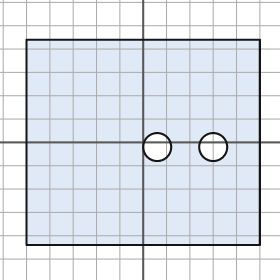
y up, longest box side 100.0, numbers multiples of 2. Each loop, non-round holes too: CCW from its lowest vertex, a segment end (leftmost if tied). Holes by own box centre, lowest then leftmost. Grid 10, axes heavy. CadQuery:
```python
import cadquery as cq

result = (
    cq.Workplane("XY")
    .moveTo(-50.0, -44.0)
    .lineTo(50.0, -44.0)
    .lineTo(50.0, 44.0)
    .lineTo(-50.0, 44.0)
    .close()
    .moveTo(6.0, -2.0)
    .circle(6.0)
    .moveTo(30.0, -2.0)
    .circle(6.0)
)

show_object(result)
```